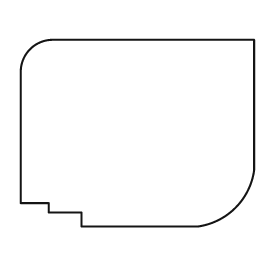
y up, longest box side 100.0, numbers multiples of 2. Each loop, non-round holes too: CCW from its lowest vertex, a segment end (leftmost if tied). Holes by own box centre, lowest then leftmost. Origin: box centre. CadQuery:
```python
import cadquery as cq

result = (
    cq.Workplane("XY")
    .moveTo(-24.0, -40.0)
    .lineTo(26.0, -40.0)
    .threePointArc((42.0, -32.0), (50.0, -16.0))
    .lineTo(50.0, 40.0)
    .lineTo(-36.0, 40.0)
    .threePointArc((-46.0, 36.0), (-50.0, 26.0))
    .lineTo(-50.0, -30.0)
    .lineTo(-38.0, -30.0)
    .lineTo(-38.0, -34.0)
    .lineTo(-24.0, -34.0)
    .close()
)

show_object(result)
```